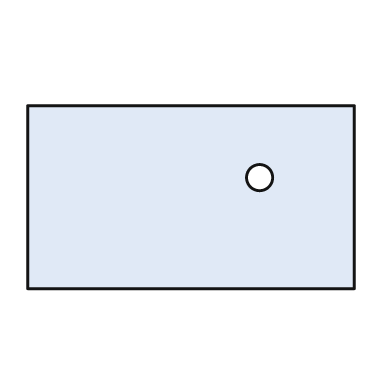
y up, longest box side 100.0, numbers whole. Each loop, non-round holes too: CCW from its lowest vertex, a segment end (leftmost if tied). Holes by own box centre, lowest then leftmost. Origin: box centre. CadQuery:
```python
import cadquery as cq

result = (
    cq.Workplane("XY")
    .moveTo(-50.0, -28.0)
    .lineTo(50.0, -28.0)
    .lineTo(50.0, 28.0)
    .lineTo(-50.0, 28.0)
    .close()
    .moveTo(21.0, 6.0)
    .circle(4.0)
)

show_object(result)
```